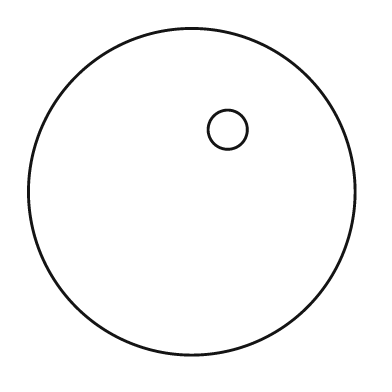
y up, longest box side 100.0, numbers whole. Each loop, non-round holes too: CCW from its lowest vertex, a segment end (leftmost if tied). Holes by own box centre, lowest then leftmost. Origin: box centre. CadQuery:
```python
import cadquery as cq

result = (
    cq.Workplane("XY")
    .moveTo(0.0, 0.0)
    .circle(50.0)
    .moveTo(11.0, 19.0)
    .circle(6.0)
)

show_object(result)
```